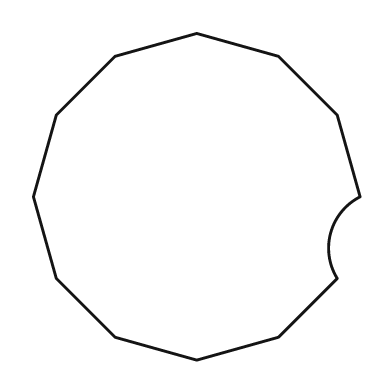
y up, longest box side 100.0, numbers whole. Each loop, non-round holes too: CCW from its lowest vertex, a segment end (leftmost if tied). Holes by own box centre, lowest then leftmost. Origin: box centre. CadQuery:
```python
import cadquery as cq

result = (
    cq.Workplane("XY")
    .moveTo(0.0, -50.0)
    .lineTo(25.0, -43.0)
    .lineTo(43.0, -25.0)
    .threePointArc((41.0, -11.0), (50.0, 0.0))
    .lineTo(43.0, 25.0)
    .lineTo(25.0, 43.0)
    .lineTo(0.0, 50.0)
    .lineTo(-25.0, 43.0)
    .lineTo(-43.0, 25.0)
    .lineTo(-50.0, 0.0)
    .lineTo(-43.0, -25.0)
    .lineTo(-25.0, -43.0)
    .close()
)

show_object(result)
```